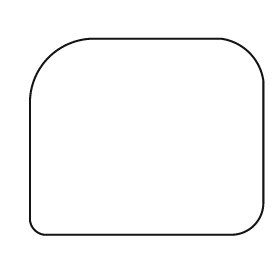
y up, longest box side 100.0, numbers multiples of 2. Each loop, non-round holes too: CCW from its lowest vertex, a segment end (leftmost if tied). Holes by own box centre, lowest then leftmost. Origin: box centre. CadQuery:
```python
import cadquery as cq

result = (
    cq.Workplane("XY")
    .moveTo(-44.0, -42.0)
    .lineTo(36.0, -42.0)
    .threePointArc((46.0, -38.0), (50.0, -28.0))
    .lineTo(50.0, 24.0)
    .threePointArc((44.0, 36.0), (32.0, 42.0))
    .lineTo(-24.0, 42.0)
    .threePointArc((-42.0, 34.0), (-50.0, 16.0))
    .lineTo(-50.0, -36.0)
    .threePointArc((-48.0, -40.0), (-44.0, -42.0))
    .close()
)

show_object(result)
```